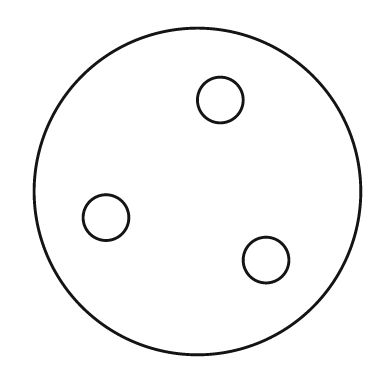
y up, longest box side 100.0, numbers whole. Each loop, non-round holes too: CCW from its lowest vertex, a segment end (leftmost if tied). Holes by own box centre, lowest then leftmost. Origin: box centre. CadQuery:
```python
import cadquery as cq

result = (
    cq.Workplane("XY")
    .moveTo(0.0, 0.0)
    .circle(50.0)
    .moveTo(21.0, -21.0)
    .circle(7.0)
    .moveTo(-28.0, -8.0)
    .circle(7.0)
    .moveTo(7.0, 28.0)
    .circle(7.0)
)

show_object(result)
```